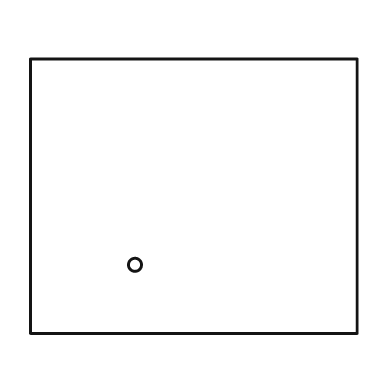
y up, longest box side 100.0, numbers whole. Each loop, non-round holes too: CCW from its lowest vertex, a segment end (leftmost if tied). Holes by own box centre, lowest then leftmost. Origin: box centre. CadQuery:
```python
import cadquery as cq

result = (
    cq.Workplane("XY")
    .moveTo(-50.0, -42.0)
    .lineTo(50.0, -42.0)
    .lineTo(50.0, 42.0)
    .lineTo(-50.0, 42.0)
    .close()
    .moveTo(-18.0, -21.0)
    .circle(2.0)
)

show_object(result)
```